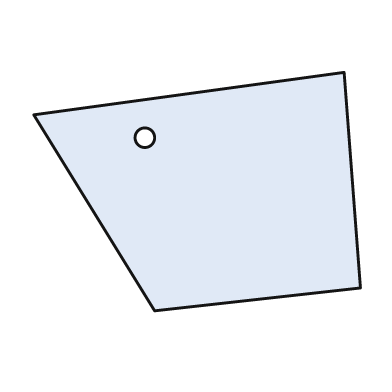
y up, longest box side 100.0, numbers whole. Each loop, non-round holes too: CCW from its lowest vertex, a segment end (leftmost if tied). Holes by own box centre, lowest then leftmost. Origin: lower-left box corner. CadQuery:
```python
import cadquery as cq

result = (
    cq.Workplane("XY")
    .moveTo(37.0, 0.0)
    .lineTo(100.0, 7.0)
    .lineTo(95.0, 73.0)
    .lineTo(0.0, 60.0)
    .close()
    .moveTo(34.0, 53.0)
    .circle(3.0)
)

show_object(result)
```